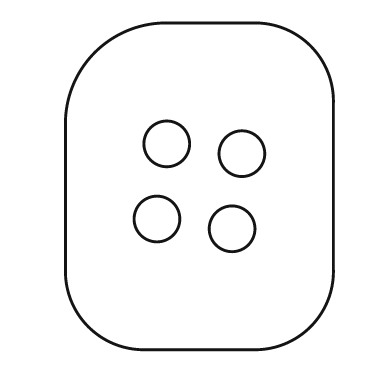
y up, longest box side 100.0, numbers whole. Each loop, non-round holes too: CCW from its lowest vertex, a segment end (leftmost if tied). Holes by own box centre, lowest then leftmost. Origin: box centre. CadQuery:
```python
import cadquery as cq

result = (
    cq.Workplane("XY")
    .moveTo(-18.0, -50.0)
    .lineTo(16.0, -50.0)
    .threePointArc((34.0, -43.0), (41.0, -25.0))
    .lineTo(41.0, 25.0)
    .threePointArc((34.0, 43.0), (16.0, 50.0))
    .lineTo(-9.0, 50.0)
    .threePointArc((-32.0, 41.0), (-41.0, 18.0))
    .lineTo(-41.0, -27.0)
    .threePointArc((-34.0, -43.0), (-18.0, -50.0))
    .close()
    .moveTo(10.0, -13.0)
    .circle(7.0)
    .moveTo(-13.0, -10.0)
    .circle(7.0)
    .moveTo(13.0, 10.0)
    .circle(7.0)
    .moveTo(-10.0, 13.0)
    .circle(7.0)
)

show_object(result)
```